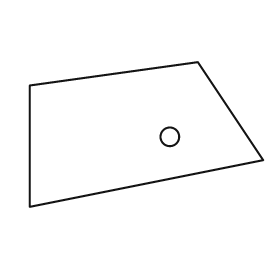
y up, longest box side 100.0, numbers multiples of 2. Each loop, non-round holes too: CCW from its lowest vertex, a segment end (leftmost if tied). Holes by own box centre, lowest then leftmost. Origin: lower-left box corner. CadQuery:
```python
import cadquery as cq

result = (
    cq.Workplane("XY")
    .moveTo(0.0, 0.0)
    .lineTo(100.0, 20.0)
    .lineTo(72.0, 62.0)
    .lineTo(0.0, 52.0)
    .close()
    .moveTo(60.0, 30.0)
    .circle(4.0)
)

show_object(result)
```